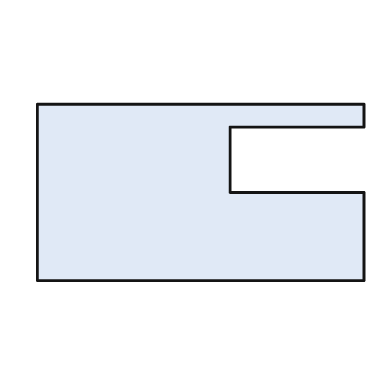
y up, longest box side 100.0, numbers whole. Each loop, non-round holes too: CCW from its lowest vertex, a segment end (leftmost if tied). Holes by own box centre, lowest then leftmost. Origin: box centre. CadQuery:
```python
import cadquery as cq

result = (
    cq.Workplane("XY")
    .moveTo(-50.0, -27.0)
    .lineTo(50.0, -27.0)
    .lineTo(50.0, 0.0)
    .lineTo(9.0, 0.0)
    .lineTo(9.0, 20.0)
    .lineTo(50.0, 20.0)
    .lineTo(50.0, 27.0)
    .lineTo(-50.0, 27.0)
    .close()
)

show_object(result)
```